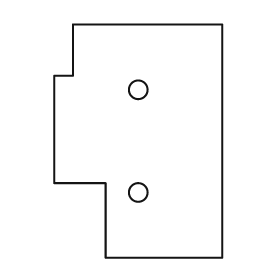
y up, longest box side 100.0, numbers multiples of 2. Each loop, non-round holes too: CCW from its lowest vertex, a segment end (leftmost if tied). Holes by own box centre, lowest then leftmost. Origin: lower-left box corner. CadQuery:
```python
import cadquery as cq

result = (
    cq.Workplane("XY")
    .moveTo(22.0, 0.0)
    .lineTo(72.0, 0.0)
    .lineTo(72.0, 100.0)
    .lineTo(8.0, 100.0)
    .lineTo(8.0, 78.0)
    .lineTo(0.0, 78.0)
    .lineTo(0.0, 32.0)
    .lineTo(22.0, 32.0)
    .close()
    .moveTo(36.0, 28.0)
    .circle(4.0)
    .moveTo(36.0, 72.0)
    .circle(4.0)
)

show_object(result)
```